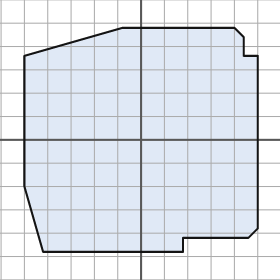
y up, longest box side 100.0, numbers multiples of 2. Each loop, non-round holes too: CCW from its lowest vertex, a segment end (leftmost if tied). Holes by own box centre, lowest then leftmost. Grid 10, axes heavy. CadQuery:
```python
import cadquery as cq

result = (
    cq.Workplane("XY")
    .moveTo(-42.0, -48.0)
    .lineTo(18.0, -48.0)
    .lineTo(18.0, -42.0)
    .lineTo(46.0, -42.0)
    .lineTo(50.0, -38.0)
    .lineTo(50.0, 36.0)
    .lineTo(44.0, 36.0)
    .lineTo(44.0, 44.0)
    .lineTo(40.0, 48.0)
    .lineTo(-8.0, 48.0)
    .lineTo(-50.0, 36.0)
    .lineTo(-50.0, -20.0)
    .close()
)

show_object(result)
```